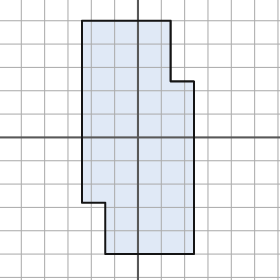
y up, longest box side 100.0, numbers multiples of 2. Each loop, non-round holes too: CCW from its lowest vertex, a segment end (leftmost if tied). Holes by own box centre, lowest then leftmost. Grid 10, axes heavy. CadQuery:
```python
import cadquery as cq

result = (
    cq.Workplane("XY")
    .moveTo(-14.0, -50.0)
    .lineTo(24.0, -50.0)
    .lineTo(24.0, 24.0)
    .lineTo(14.0, 24.0)
    .lineTo(14.0, 50.0)
    .lineTo(-24.0, 50.0)
    .lineTo(-24.0, -28.0)
    .lineTo(-14.0, -28.0)
    .close()
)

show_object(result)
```